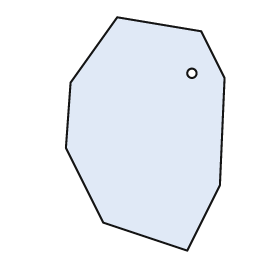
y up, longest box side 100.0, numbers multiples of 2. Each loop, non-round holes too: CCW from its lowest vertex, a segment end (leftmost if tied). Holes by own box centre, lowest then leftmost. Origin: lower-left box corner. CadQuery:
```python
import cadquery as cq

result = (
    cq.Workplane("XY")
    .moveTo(52.0, 0.0)
    .lineTo(66.0, 28.0)
    .lineTo(68.0, 74.0)
    .lineTo(58.0, 94.0)
    .lineTo(22.0, 100.0)
    .lineTo(2.0, 72.0)
    .lineTo(0.0, 44.0)
    .lineTo(16.0, 12.0)
    .close()
    .moveTo(54.0, 76.0)
    .circle(2.0)
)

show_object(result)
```